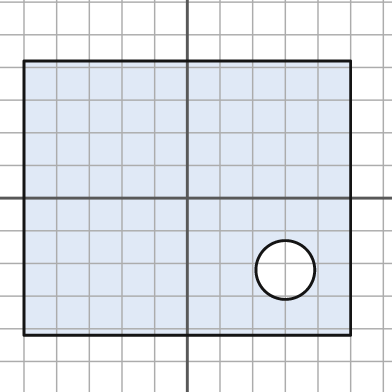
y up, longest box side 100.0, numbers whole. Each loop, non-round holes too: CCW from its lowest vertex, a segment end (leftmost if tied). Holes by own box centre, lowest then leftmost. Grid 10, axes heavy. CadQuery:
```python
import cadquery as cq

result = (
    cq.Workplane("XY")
    .moveTo(-50.0, -42.0)
    .lineTo(50.0, -42.0)
    .lineTo(50.0, 42.0)
    .lineTo(-50.0, 42.0)
    .close()
    .moveTo(30.0, -22.0)
    .circle(9.0)
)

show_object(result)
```